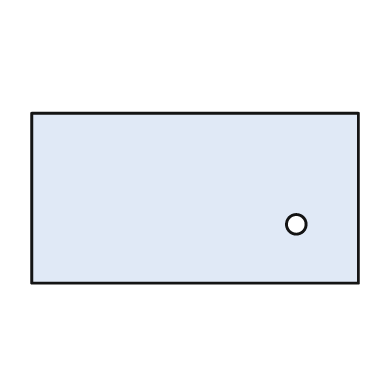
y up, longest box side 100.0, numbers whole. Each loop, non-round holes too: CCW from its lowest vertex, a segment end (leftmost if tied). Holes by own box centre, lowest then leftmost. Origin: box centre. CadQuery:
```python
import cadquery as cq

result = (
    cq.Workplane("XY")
    .moveTo(-50.0, -26.0)
    .lineTo(50.0, -26.0)
    .lineTo(50.0, 26.0)
    .lineTo(-50.0, 26.0)
    .close()
    .moveTo(31.0, -8.0)
    .circle(3.0)
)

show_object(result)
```